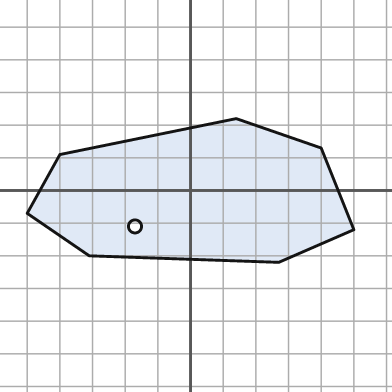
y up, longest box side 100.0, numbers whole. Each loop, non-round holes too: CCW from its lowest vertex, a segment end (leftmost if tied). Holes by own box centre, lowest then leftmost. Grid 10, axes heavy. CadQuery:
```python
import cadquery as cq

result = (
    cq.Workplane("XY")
    .moveTo(27.0, -22.0)
    .lineTo(50.0, -12.0)
    .lineTo(40.0, 13.0)
    .lineTo(14.0, 22.0)
    .lineTo(-40.0, 11.0)
    .lineTo(-50.0, -7.0)
    .lineTo(-31.0, -20.0)
    .close()
    .moveTo(-17.0, -11.0)
    .circle(2.0)
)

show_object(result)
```